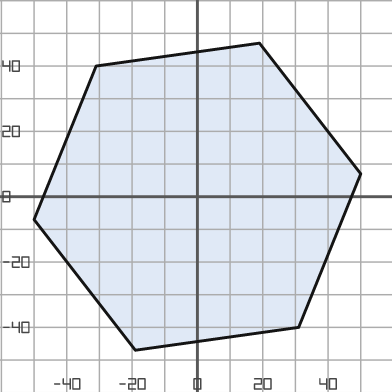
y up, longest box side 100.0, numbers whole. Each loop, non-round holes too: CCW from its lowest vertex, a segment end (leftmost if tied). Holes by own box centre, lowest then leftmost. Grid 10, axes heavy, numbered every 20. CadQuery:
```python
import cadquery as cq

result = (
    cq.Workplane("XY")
    .moveTo(-19.0, -47.0)
    .lineTo(31.0, -40.0)
    .lineTo(50.0, 7.0)
    .lineTo(19.0, 47.0)
    .lineTo(-31.0, 40.0)
    .lineTo(-50.0, -7.0)
    .close()
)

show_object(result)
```